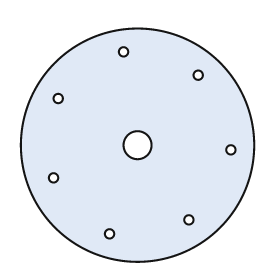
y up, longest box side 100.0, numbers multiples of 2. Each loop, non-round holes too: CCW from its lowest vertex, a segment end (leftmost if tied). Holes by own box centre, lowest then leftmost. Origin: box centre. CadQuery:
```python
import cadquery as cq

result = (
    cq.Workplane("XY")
    .moveTo(0.0, 0.0)
    .circle(50.0)
    .moveTo(-12.0, -38.0)
    .circle(2.0)
    .moveTo(22.0, -32.0)
    .circle(2.0)
    .moveTo(-36.0, -14.0)
    .circle(2.0)
    .moveTo(40.0, -2.0)
    .circle(2.0)
    .moveTo(0.0, 0.0)
    .circle(6.0)
    .moveTo(-34.0, 20.0)
    .circle(2.0)
    .moveTo(26.0, 30.0)
    .circle(2.0)
    .moveTo(-6.0, 40.0)
    .circle(2.0)
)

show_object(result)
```